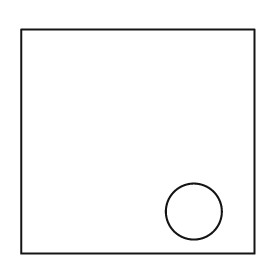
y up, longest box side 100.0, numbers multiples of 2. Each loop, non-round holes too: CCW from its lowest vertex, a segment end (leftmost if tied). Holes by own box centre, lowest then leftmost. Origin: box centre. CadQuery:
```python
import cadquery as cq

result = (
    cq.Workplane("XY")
    .moveTo(-50.0, -48.0)
    .lineTo(50.0, -48.0)
    .lineTo(50.0, 48.0)
    .lineTo(-50.0, 48.0)
    .close()
    .moveTo(24.0, -30.0)
    .circle(12.0)
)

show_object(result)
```